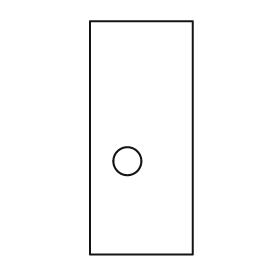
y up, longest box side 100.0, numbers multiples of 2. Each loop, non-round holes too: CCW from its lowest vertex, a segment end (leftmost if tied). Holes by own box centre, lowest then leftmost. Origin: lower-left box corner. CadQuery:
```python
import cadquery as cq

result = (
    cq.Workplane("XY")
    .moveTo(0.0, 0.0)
    .lineTo(44.0, 0.0)
    .lineTo(44.0, 100.0)
    .lineTo(0.0, 100.0)
    .close()
    .moveTo(16.0, 40.0)
    .circle(6.0)
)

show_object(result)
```